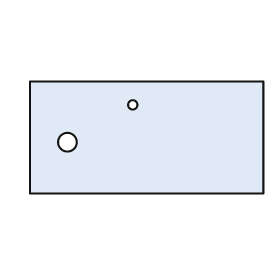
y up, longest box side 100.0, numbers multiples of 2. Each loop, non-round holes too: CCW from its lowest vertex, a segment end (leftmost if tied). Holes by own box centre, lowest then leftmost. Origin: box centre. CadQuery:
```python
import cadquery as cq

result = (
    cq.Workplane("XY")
    .moveTo(-50.0, -24.0)
    .lineTo(50.0, -24.0)
    .lineTo(50.0, 24.0)
    .lineTo(-50.0, 24.0)
    .close()
    .moveTo(-34.0, -2.0)
    .circle(4.0)
    .moveTo(-6.0, 14.0)
    .circle(2.0)
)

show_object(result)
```